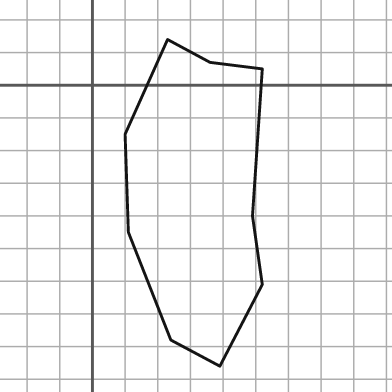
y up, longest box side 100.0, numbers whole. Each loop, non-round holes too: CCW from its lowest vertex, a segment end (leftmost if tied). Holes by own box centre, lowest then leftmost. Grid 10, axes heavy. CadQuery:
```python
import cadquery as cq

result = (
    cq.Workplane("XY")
    .moveTo(39.0, -86.0)
    .lineTo(52.0, -61.0)
    .lineTo(49.0, -40.0)
    .lineTo(52.0, 5.0)
    .lineTo(36.0, 7.0)
    .lineTo(23.0, 14.0)
    .lineTo(10.0, -15.0)
    .lineTo(11.0, -45.0)
    .lineTo(24.0, -78.0)
    .close()
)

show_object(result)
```